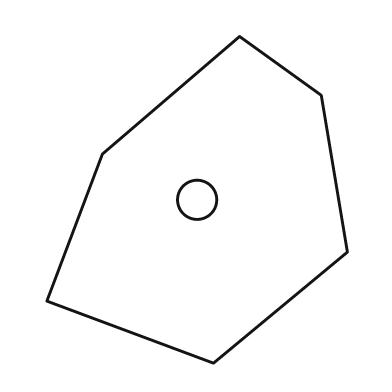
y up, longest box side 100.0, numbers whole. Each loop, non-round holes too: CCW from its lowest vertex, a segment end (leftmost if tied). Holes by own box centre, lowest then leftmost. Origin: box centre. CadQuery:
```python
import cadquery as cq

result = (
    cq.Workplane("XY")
    .moveTo(5.0, -50.0)
    .lineTo(46.0, -16.0)
    .lineTo(38.0, 32.0)
    .lineTo(13.0, 50.0)
    .lineTo(-29.0, 14.0)
    .lineTo(-46.0, -31.0)
    .close()
    .moveTo(0.0, 0.0)
    .circle(6.0)
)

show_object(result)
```